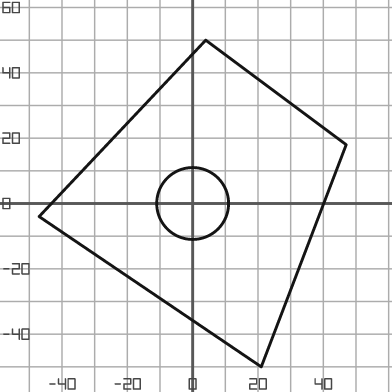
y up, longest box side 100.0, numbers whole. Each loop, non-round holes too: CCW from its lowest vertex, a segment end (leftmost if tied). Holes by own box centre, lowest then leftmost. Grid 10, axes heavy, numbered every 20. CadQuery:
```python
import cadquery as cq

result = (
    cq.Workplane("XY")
    .moveTo(21.0, -50.0)
    .lineTo(47.0, 18.0)
    .lineTo(4.0, 50.0)
    .lineTo(-47.0, -4.0)
    .close()
    .moveTo(0.0, 0.0)
    .circle(11.0)
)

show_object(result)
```